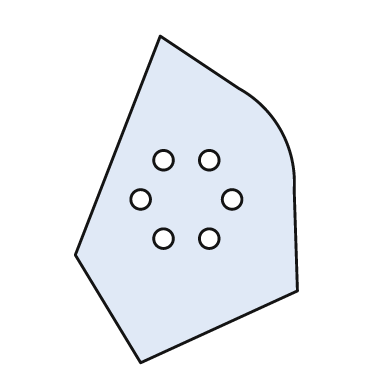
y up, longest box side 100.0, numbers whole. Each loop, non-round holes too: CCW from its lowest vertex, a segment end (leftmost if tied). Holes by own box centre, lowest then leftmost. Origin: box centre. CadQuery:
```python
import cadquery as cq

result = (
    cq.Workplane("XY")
    .moveTo(-14.0, -50.0)
    .lineTo(34.0, -28.0)
    .lineTo(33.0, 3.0)
    .threePointArc((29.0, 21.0), (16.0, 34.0))
    .lineTo(-8.0, 50.0)
    .lineTo(-34.0, -17.0)
    .close()
    .moveTo(-7.0, -12.0)
    .circle(3.0)
    .moveTo(7.0, -12.0)
    .circle(3.0)
    .moveTo(-14.0, 0.0)
    .circle(3.0)
    .moveTo(14.0, 0.0)
    .circle(3.0)
    .moveTo(-7.0, 12.0)
    .circle(3.0)
    .moveTo(7.0, 12.0)
    .circle(3.0)
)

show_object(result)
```